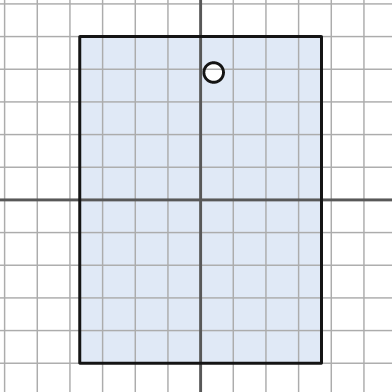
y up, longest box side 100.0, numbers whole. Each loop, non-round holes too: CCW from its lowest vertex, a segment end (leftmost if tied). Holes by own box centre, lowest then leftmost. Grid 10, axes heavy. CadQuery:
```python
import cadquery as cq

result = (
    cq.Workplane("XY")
    .moveTo(-37.0, -50.0)
    .lineTo(37.0, -50.0)
    .lineTo(37.0, 50.0)
    .lineTo(-37.0, 50.0)
    .close()
    .moveTo(4.0, 39.0)
    .circle(3.0)
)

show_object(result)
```